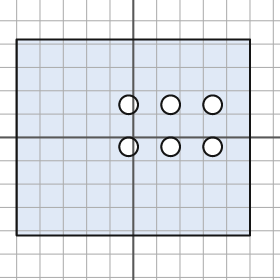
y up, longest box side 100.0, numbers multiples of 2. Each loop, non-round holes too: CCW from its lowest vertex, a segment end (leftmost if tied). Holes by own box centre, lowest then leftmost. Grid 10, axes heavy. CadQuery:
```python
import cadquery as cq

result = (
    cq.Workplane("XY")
    .moveTo(-50.0, -42.0)
    .lineTo(50.0, -42.0)
    .lineTo(50.0, 42.0)
    .lineTo(-50.0, 42.0)
    .close()
    .moveTo(-2.0, -4.0)
    .circle(4.0)
    .moveTo(16.0, -4.0)
    .circle(4.0)
    .moveTo(34.0, -4.0)
    .circle(4.0)
    .moveTo(-2.0, 14.0)
    .circle(4.0)
    .moveTo(16.0, 14.0)
    .circle(4.0)
    .moveTo(34.0, 14.0)
    .circle(4.0)
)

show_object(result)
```